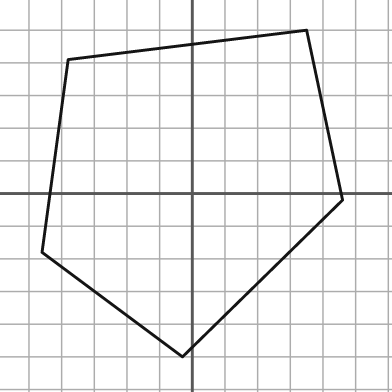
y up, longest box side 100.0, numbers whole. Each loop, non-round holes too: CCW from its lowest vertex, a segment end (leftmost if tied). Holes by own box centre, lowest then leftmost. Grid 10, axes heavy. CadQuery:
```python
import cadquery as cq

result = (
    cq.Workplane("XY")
    .moveTo(-3.0, -50.0)
    .lineTo(46.0, -2.0)
    .lineTo(35.0, 50.0)
    .lineTo(-38.0, 41.0)
    .lineTo(-46.0, -18.0)
    .close()
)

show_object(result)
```